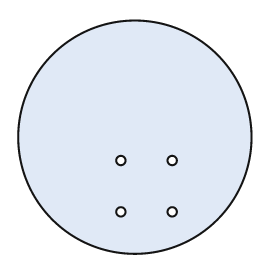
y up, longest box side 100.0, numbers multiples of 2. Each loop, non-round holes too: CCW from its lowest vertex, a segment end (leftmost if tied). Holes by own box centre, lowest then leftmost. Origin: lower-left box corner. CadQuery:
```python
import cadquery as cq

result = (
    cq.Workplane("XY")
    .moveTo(50.0, 50.0)
    .circle(50.0)
    .moveTo(44.0, 18.0)
    .circle(2.0)
    .moveTo(66.0, 18.0)
    .circle(2.0)
    .moveTo(44.0, 40.0)
    .circle(2.0)
    .moveTo(66.0, 40.0)
    .circle(2.0)
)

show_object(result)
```